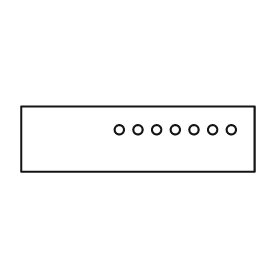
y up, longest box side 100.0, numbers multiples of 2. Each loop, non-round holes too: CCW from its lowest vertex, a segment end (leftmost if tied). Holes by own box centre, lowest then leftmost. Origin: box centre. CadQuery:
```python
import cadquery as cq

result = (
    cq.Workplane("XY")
    .moveTo(-50.0, -14.0)
    .lineTo(50.0, -14.0)
    .lineTo(50.0, 14.0)
    .lineTo(-50.0, 14.0)
    .close()
    .moveTo(-8.0, 4.0)
    .circle(2.0)
    .moveTo(0.0, 4.0)
    .circle(2.0)
    .moveTo(8.0, 4.0)
    .circle(2.0)
    .moveTo(16.0, 4.0)
    .circle(2.0)
    .moveTo(24.0, 4.0)
    .circle(2.0)
    .moveTo(32.0, 4.0)
    .circle(2.0)
    .moveTo(40.0, 4.0)
    .circle(2.0)
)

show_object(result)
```